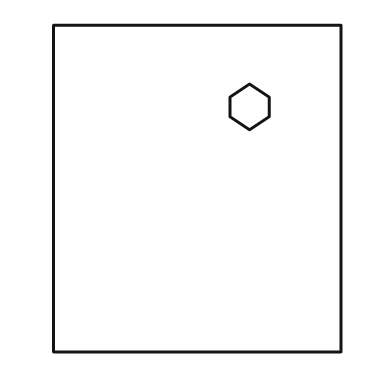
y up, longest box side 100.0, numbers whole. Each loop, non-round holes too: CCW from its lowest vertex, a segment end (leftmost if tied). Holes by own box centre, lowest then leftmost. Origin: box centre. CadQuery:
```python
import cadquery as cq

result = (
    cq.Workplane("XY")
    .moveTo(-44.0, -50.0)
    .lineTo(44.0, -50.0)
    .lineTo(44.0, 50.0)
    .lineTo(-44.0, 50.0)
    .close()
    .moveTo(16.0, 18.0)
    .lineTo(22.0, 22.0)
    .lineTo(22.0, 28.0)
    .lineTo(16.0, 32.0)
    .lineTo(10.0, 28.0)
    .lineTo(10.0, 22.0)
    .close()
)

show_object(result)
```